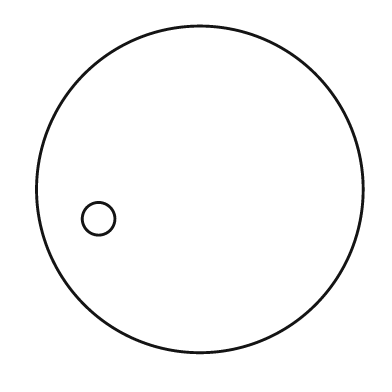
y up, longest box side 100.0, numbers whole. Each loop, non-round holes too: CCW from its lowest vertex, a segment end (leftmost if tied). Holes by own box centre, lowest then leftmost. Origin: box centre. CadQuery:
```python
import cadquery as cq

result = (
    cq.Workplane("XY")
    .moveTo(0.0, 0.0)
    .circle(50.0)
    .moveTo(-31.0, -9.0)
    .circle(5.0)
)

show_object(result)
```